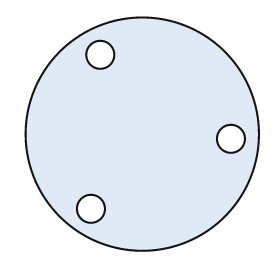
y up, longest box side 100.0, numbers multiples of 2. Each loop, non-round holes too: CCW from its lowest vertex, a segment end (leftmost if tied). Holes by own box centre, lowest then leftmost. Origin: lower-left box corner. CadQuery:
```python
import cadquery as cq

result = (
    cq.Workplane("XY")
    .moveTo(50.0, 50.0)
    .circle(50.0)
    .moveTo(28.0, 18.0)
    .circle(6.0)
    .moveTo(88.0, 48.0)
    .circle(6.0)
    .moveTo(32.0, 84.0)
    .circle(6.0)
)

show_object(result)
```